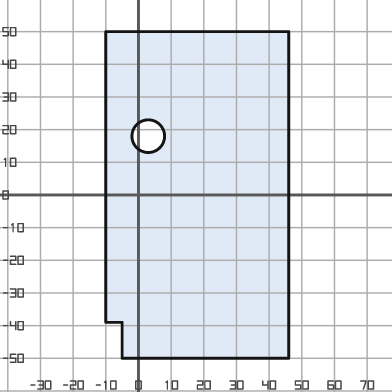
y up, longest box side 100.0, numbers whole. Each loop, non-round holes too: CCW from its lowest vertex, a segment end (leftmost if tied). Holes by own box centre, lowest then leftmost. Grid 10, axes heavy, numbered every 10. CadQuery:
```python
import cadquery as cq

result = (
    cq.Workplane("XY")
    .moveTo(-5.0, -50.0)
    .lineTo(46.0, -50.0)
    .lineTo(46.0, 50.0)
    .lineTo(-10.0, 50.0)
    .lineTo(-10.0, -39.0)
    .lineTo(-5.0, -39.0)
    .close()
    .moveTo(3.0, 18.0)
    .circle(5.0)
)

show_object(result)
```